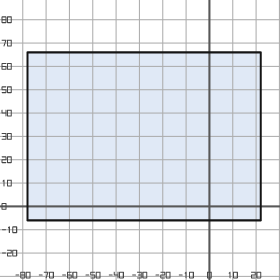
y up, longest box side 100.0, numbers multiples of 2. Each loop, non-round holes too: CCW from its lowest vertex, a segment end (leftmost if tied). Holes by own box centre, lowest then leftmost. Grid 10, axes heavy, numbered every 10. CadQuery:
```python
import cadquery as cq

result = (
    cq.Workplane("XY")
    .moveTo(-78.0, -6.0)
    .lineTo(22.0, -6.0)
    .lineTo(22.0, 66.0)
    .lineTo(-78.0, 66.0)
    .close()
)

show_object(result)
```